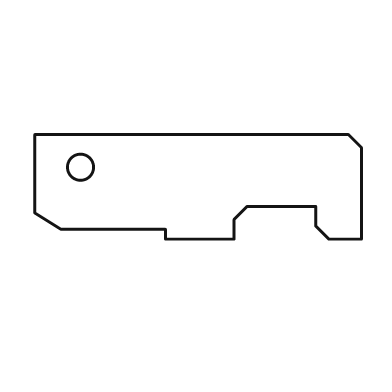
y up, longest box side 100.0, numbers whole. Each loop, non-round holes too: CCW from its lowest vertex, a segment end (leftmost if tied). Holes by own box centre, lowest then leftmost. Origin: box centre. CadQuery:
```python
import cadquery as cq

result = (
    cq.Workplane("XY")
    .moveTo(-10.0, -16.0)
    .lineTo(11.0, -16.0)
    .lineTo(11.0, -10.0)
    .lineTo(15.0, -6.0)
    .lineTo(36.0, -6.0)
    .lineTo(36.0, -12.0)
    .lineTo(40.0, -16.0)
    .lineTo(50.0, -16.0)
    .lineTo(50.0, 12.0)
    .lineTo(46.0, 16.0)
    .lineTo(-50.0, 16.0)
    .lineTo(-50.0, -8.0)
    .lineTo(-42.0, -13.0)
    .lineTo(-10.0, -13.0)
    .close()
    .moveTo(-36.0, 6.0)
    .circle(4.0)
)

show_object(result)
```